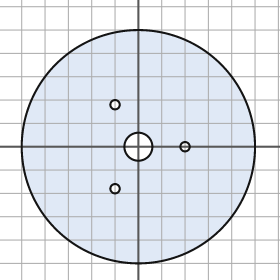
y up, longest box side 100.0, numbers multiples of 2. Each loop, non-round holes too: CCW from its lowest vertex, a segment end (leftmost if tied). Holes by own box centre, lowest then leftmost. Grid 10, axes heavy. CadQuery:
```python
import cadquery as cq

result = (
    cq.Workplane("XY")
    .moveTo(0.0, 0.0)
    .circle(50.0)
    .moveTo(-10.0, -18.0)
    .circle(2.0)
    .moveTo(0.0, 0.0)
    .circle(6.0)
    .moveTo(20.0, 0.0)
    .circle(2.0)
    .moveTo(-10.0, 18.0)
    .circle(2.0)
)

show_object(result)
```